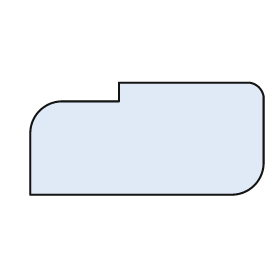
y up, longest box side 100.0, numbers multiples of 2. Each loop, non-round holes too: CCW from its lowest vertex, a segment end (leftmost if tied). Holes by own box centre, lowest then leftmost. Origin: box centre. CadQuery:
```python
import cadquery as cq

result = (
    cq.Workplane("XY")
    .moveTo(-50.0, -24.0)
    .lineTo(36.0, -24.0)
    .threePointArc((46.0, -20.0), (50.0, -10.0))
    .lineTo(50.0, 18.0)
    .threePointArc((48.0, 22.0), (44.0, 24.0))
    .lineTo(-12.0, 24.0)
    .lineTo(-12.0, 16.0)
    .lineTo(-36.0, 16.0)
    .threePointArc((-46.0, 12.0), (-50.0, 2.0))
    .close()
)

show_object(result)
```